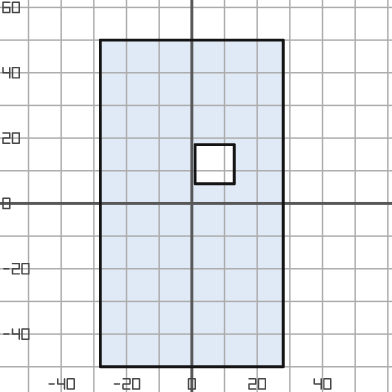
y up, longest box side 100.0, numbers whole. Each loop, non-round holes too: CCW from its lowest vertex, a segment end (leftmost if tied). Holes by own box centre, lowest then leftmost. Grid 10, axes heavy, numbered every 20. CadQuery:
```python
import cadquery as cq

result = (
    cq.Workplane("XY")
    .moveTo(-28.0, -50.0)
    .lineTo(28.0, -50.0)
    .lineTo(28.0, 50.0)
    .lineTo(-28.0, 50.0)
    .close()
    .moveTo(1.0, 6.0)
    .lineTo(13.0, 6.0)
    .lineTo(13.0, 18.0)
    .lineTo(1.0, 18.0)
    .close()
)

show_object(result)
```